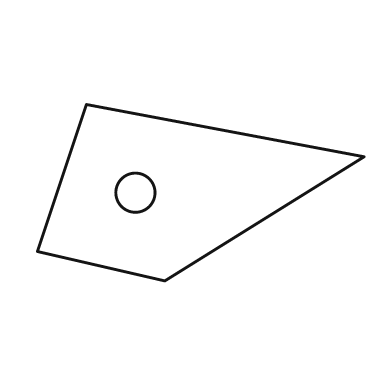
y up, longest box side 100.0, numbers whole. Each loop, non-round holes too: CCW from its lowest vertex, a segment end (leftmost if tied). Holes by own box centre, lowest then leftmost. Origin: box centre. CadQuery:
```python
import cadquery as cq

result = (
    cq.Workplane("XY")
    .moveTo(-11.0, -27.0)
    .lineTo(50.0, 11.0)
    .lineTo(-35.0, 27.0)
    .lineTo(-50.0, -18.0)
    .close()
    .moveTo(-20.0, 0.0)
    .circle(6.0)
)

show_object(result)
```